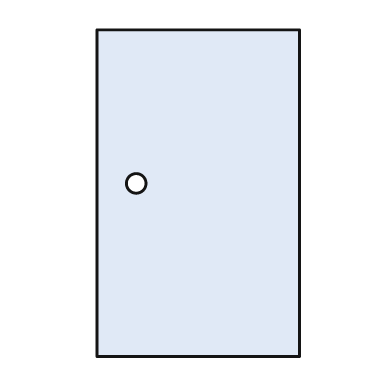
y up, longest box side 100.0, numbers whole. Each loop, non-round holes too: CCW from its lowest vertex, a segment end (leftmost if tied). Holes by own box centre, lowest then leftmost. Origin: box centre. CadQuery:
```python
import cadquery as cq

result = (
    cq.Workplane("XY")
    .moveTo(-31.0, -50.0)
    .lineTo(31.0, -50.0)
    .lineTo(31.0, 50.0)
    .lineTo(-31.0, 50.0)
    .close()
    .moveTo(-19.0, 3.0)
    .circle(3.0)
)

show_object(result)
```